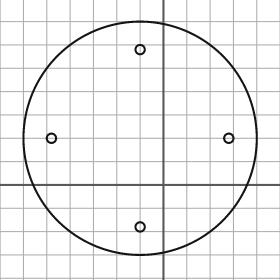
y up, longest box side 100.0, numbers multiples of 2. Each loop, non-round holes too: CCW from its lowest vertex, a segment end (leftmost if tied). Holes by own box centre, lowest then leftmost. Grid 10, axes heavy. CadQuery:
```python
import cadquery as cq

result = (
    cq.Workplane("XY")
    .moveTo(-10.0, 20.0)
    .circle(50.0)
    .moveTo(-10.0, -18.0)
    .circle(2.0)
    .moveTo(-48.0, 20.0)
    .circle(2.0)
    .moveTo(28.0, 20.0)
    .circle(2.0)
    .moveTo(-10.0, 58.0)
    .circle(2.0)
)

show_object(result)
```